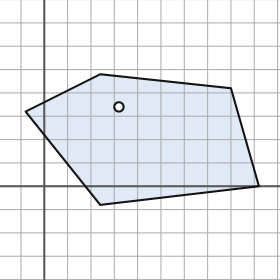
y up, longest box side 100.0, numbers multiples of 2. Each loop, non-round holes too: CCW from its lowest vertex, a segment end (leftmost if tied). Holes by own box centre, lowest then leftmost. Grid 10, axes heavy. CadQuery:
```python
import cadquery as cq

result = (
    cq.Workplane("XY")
    .moveTo(24.0, -8.0)
    .lineTo(92.0, 0.0)
    .lineTo(80.0, 42.0)
    .lineTo(24.0, 48.0)
    .lineTo(-8.0, 32.0)
    .close()
    .moveTo(32.0, 34.0)
    .circle(2.0)
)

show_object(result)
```